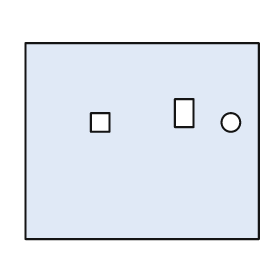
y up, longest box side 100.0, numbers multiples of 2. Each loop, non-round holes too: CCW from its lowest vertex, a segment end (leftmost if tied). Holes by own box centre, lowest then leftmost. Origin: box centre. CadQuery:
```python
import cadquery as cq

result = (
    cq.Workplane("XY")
    .moveTo(-50.0, -42.0)
    .lineTo(50.0, -42.0)
    .lineTo(50.0, 42.0)
    .lineTo(-50.0, 42.0)
    .close()
    .moveTo(-22.0, 4.0)
    .lineTo(-14.0, 4.0)
    .lineTo(-14.0, 12.0)
    .lineTo(-22.0, 12.0)
    .close()
    .moveTo(38.0, 8.0)
    .circle(4.0)
    .moveTo(14.0, 6.0)
    .lineTo(22.0, 6.0)
    .lineTo(22.0, 18.0)
    .lineTo(14.0, 18.0)
    .close()
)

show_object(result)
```